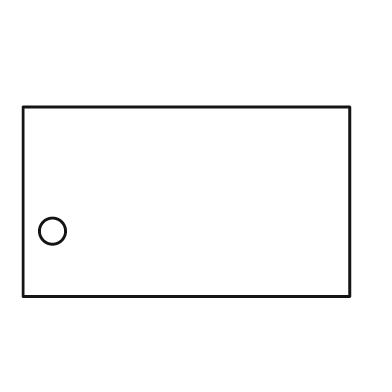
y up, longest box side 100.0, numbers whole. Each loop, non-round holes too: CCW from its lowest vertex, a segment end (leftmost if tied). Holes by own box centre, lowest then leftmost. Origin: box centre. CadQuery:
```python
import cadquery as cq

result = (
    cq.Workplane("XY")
    .moveTo(-50.0, -29.0)
    .lineTo(50.0, -29.0)
    .lineTo(50.0, 29.0)
    .lineTo(-50.0, 29.0)
    .close()
    .moveTo(-41.0, -9.0)
    .circle(4.0)
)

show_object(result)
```